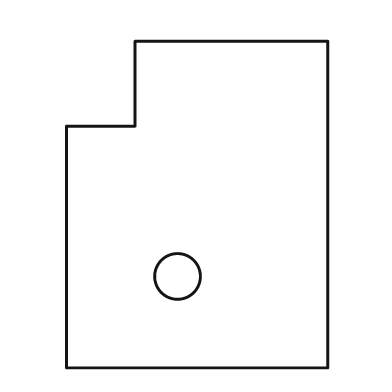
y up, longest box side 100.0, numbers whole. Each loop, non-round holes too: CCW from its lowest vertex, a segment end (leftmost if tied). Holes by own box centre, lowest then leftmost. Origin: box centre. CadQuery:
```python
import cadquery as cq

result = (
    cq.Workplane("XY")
    .moveTo(-40.0, -50.0)
    .lineTo(40.0, -50.0)
    .lineTo(40.0, 50.0)
    .lineTo(-19.0, 50.0)
    .lineTo(-19.0, 24.0)
    .lineTo(-40.0, 24.0)
    .close()
    .moveTo(-6.0, -22.0)
    .circle(7.0)
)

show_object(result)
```